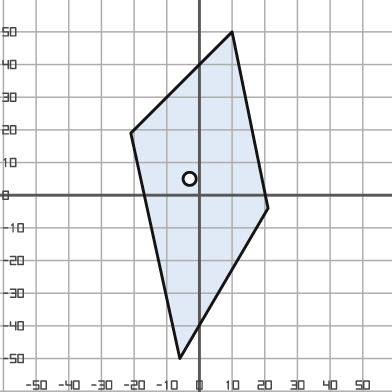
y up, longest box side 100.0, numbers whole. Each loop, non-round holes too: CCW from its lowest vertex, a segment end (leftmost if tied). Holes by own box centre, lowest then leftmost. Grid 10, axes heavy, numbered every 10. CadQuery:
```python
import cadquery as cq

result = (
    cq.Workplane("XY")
    .moveTo(-6.0, -50.0)
    .lineTo(21.0, -4.0)
    .lineTo(10.0, 50.0)
    .lineTo(-21.0, 19.0)
    .close()
    .moveTo(-3.0, 5.0)
    .circle(2.0)
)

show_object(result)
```